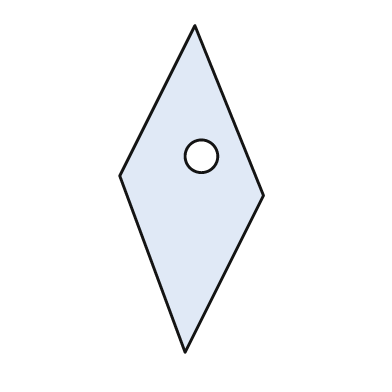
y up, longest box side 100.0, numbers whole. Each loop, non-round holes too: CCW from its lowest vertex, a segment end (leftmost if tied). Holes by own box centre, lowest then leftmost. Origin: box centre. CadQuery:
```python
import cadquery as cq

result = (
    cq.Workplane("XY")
    .moveTo(-2.0, -50.0)
    .lineTo(22.0, -2.0)
    .lineTo(1.0, 50.0)
    .lineTo(-22.0, 4.0)
    .close()
    .moveTo(3.0, 10.0)
    .circle(5.0)
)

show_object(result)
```